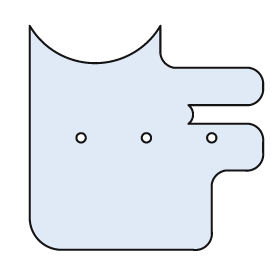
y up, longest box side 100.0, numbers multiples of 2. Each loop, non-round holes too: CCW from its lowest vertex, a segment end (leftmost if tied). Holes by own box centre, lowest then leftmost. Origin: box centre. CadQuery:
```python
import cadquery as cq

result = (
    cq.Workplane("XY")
    .moveTo(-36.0, -48.0)
    .lineTo(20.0, -48.0)
    .threePointArc((26.0, -46.0), (28.0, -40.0))
    .lineTo(28.0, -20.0)
    .threePointArc((30.0, -16.0), (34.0, -14.0))
    .lineTo(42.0, -14.0)
    .threePointArc((48.0, -12.0), (50.0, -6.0))
    .lineTo(50.0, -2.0)
    .threePointArc((48.0, 4.0), (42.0, 6.0))
    .lineTo(18.0, 6.0)
    .threePointArc((20.0, 10.0), (18.0, 14.0))
    .lineTo(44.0, 14.0)
    .threePointArc((48.0, 16.0), (50.0, 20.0))
    .lineTo(50.0, 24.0)
    .threePointArc((48.0, 28.0), (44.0, 30.0))
    .lineTo(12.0, 30.0)
    .threePointArc((8.0, 32.0), (6.0, 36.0))
    .lineTo(6.0, 48.0)
    .threePointArc((-22.0, 32.0), (-50.0, 48.0))
    .lineTo(-50.0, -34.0)
    .threePointArc((-46.0, -44.0), (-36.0, -48.0))
    .close()
    .moveTo(-28.0, 0.0)
    .circle(2.0)
    .moveTo(0.0, 0.0)
    .circle(2.0)
    .moveTo(28.0, 0.0)
    .circle(2.0)
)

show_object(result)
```